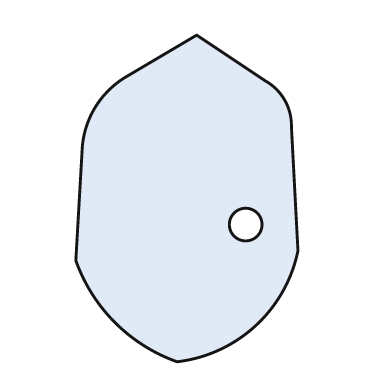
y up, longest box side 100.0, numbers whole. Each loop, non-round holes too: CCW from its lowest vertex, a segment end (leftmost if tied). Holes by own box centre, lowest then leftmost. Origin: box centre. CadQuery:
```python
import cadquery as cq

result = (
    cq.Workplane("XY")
    .moveTo(-3.0, -50.0)
    .threePointArc((21.0, -39.0), (34.0, -16.0))
    .lineTo(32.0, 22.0)
    .threePointArc((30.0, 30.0), (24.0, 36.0))
    .lineTo(3.0, 50.0)
    .lineTo(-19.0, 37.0)
    .threePointArc((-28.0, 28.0), (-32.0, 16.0))
    .lineTo(-34.0, -19.0)
    .threePointArc((-22.0, -38.0), (-3.0, -50.0))
    .close()
    .moveTo(18.0, -8.0)
    .circle(5.0)
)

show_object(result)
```